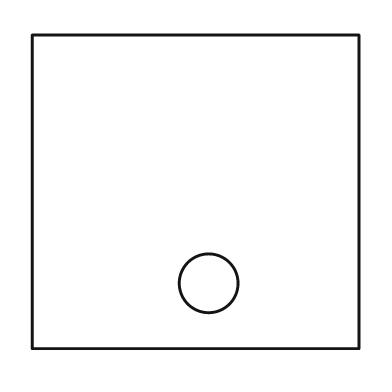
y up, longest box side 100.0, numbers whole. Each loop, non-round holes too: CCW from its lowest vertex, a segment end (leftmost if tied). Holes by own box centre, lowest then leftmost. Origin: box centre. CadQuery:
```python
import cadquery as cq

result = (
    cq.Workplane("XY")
    .moveTo(-50.0, -48.0)
    .lineTo(50.0, -48.0)
    .lineTo(50.0, 48.0)
    .lineTo(-50.0, 48.0)
    .close()
    .moveTo(4.0, -28.0)
    .circle(9.0)
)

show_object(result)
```